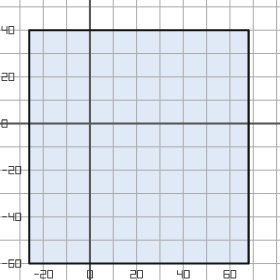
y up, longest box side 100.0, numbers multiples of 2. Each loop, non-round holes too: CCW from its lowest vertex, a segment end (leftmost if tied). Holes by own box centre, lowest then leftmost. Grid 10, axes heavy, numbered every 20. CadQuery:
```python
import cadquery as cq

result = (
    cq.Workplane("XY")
    .moveTo(-26.0, -60.0)
    .lineTo(68.0, -60.0)
    .lineTo(68.0, 40.0)
    .lineTo(-26.0, 40.0)
    .close()
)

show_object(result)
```